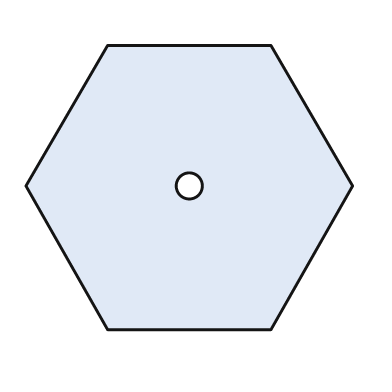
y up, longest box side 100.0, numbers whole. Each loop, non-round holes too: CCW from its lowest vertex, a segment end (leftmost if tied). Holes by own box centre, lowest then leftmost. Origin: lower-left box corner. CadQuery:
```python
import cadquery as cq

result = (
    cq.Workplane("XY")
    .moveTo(25.0, 0.0)
    .lineTo(75.0, 0.0)
    .lineTo(100.0, 44.0)
    .lineTo(75.0, 87.0)
    .lineTo(25.0, 87.0)
    .lineTo(0.0, 44.0)
    .close()
    .moveTo(50.0, 44.0)
    .circle(4.0)
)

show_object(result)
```